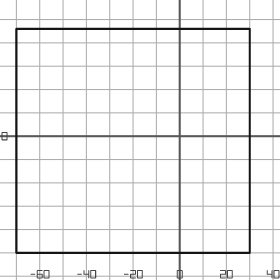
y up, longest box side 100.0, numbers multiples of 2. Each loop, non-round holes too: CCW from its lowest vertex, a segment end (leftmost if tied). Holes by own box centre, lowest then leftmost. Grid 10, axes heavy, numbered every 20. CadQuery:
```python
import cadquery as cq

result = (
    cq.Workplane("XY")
    .moveTo(-70.0, -50.0)
    .lineTo(30.0, -50.0)
    .lineTo(30.0, 46.0)
    .lineTo(-70.0, 46.0)
    .close()
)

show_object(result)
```